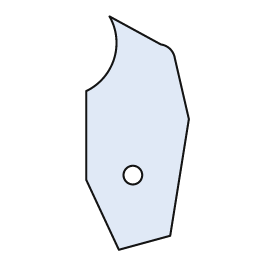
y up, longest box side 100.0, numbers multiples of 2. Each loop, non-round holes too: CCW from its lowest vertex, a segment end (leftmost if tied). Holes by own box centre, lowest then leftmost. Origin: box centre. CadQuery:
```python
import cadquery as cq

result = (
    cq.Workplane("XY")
    .moveTo(-8.0, -50.0)
    .lineTo(14.0, -44.0)
    .lineTo(22.0, 6.0)
    .lineTo(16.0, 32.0)
    .threePointArc((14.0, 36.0), (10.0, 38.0))
    .lineTo(-12.0, 50.0)
    .threePointArc((-10.0, 32.0), (-22.0, 18.0))
    .lineTo(-22.0, -20.0)
    .close()
    .moveTo(-2.0, -18.0)
    .circle(4.0)
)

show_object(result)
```